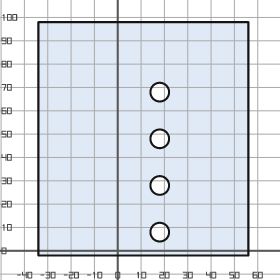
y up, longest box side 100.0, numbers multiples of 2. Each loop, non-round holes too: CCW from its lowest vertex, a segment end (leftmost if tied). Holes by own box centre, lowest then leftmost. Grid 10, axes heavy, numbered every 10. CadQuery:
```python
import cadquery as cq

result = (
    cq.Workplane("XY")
    .moveTo(-34.0, -2.0)
    .lineTo(56.0, -2.0)
    .lineTo(56.0, 98.0)
    .lineTo(-34.0, 98.0)
    .close()
    .moveTo(18.0, 8.0)
    .circle(4.0)
    .moveTo(18.0, 28.0)
    .circle(4.0)
    .moveTo(18.0, 48.0)
    .circle(4.0)
    .moveTo(18.0, 68.0)
    .circle(4.0)
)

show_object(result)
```